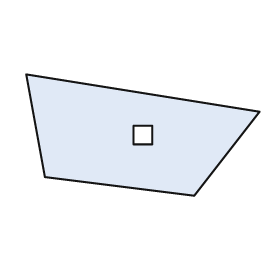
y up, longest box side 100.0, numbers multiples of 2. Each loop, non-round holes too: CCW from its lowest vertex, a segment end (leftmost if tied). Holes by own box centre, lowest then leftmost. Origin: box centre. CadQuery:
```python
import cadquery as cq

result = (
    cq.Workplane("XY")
    .moveTo(22.0, -26.0)
    .lineTo(50.0, 10.0)
    .lineTo(-50.0, 26.0)
    .lineTo(-42.0, -18.0)
    .close()
    .moveTo(-4.0, -4.0)
    .lineTo(4.0, -4.0)
    .lineTo(4.0, 4.0)
    .lineTo(-4.0, 4.0)
    .close()
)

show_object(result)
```